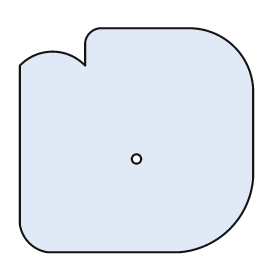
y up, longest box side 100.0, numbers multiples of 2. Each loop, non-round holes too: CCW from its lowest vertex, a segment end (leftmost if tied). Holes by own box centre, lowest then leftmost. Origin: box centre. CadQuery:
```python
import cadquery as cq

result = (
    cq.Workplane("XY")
    .moveTo(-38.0, -48.0)
    .lineTo(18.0, -48.0)
    .threePointArc((40.0, -38.0), (50.0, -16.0))
    .lineTo(50.0, 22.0)
    .threePointArc((42.0, 40.0), (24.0, 48.0))
    .lineTo(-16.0, 48.0)
    .threePointArc((-20.0, 46.0), (-22.0, 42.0))
    .lineTo(-22.0, 32.0)
    .threePointArc((-36.0, 38.0), (-50.0, 32.0))
    .lineTo(-50.0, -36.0)
    .threePointArc((-46.0, -44.0), (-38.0, -48.0))
    .close()
    .moveTo(0.0, -8.0)
    .circle(2.0)
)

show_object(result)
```